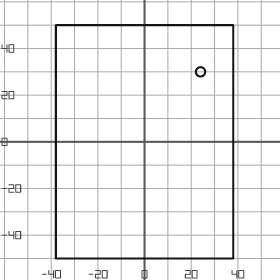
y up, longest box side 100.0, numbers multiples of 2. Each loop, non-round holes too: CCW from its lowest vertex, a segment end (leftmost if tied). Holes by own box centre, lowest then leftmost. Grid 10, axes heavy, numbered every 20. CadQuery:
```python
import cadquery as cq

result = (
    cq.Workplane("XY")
    .moveTo(-38.0, -50.0)
    .lineTo(38.0, -50.0)
    .lineTo(38.0, 50.0)
    .lineTo(-38.0, 50.0)
    .close()
    .moveTo(24.0, 30.0)
    .circle(2.0)
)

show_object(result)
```